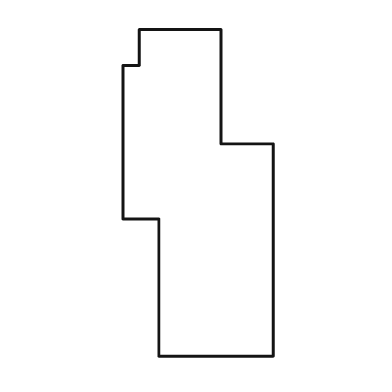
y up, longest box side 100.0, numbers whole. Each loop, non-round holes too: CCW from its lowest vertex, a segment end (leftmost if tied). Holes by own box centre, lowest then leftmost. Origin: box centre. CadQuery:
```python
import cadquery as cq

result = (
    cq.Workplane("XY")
    .moveTo(-12.0, -50.0)
    .lineTo(23.0, -50.0)
    .lineTo(23.0, 15.0)
    .lineTo(7.0, 15.0)
    .lineTo(7.0, 50.0)
    .lineTo(-18.0, 50.0)
    .lineTo(-18.0, 39.0)
    .lineTo(-23.0, 39.0)
    .lineTo(-23.0, -8.0)
    .lineTo(-12.0, -8.0)
    .close()
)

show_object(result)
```